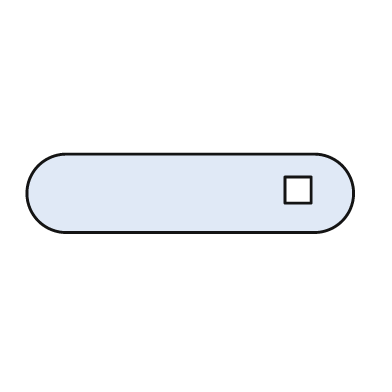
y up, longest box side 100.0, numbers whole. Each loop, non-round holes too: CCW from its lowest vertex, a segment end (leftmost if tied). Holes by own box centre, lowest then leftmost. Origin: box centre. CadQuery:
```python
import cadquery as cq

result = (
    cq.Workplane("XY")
    .moveTo(-38.0, -12.0)
    .lineTo(38.0, -12.0)
    .threePointArc((50.0, 0.0), (38.0, 12.0))
    .lineTo(-38.0, 12.0)
    .threePointArc((-50.0, 0.0), (-38.0, -12.0))
    .close()
    .moveTo(29.0, -3.0)
    .lineTo(37.0, -3.0)
    .lineTo(37.0, 5.0)
    .lineTo(29.0, 5.0)
    .close()
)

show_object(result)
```